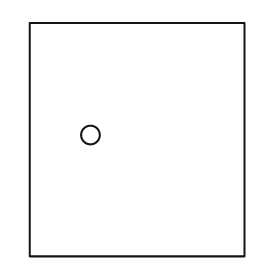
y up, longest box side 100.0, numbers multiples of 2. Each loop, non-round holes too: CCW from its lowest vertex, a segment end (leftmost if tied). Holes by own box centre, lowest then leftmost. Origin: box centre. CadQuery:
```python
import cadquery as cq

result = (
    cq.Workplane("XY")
    .moveTo(-46.0, -50.0)
    .lineTo(46.0, -50.0)
    .lineTo(46.0, 50.0)
    .lineTo(-46.0, 50.0)
    .close()
    .moveTo(-20.0, 2.0)
    .circle(4.0)
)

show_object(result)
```